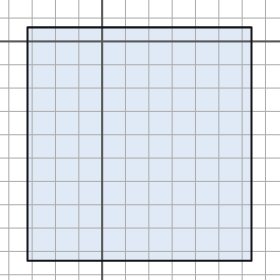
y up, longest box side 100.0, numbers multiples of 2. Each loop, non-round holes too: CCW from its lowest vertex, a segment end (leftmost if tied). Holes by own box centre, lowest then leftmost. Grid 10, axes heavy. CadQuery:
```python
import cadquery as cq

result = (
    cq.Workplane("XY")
    .moveTo(-32.0, -94.0)
    .lineTo(64.0, -94.0)
    .lineTo(64.0, 6.0)
    .lineTo(-32.0, 6.0)
    .close()
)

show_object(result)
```